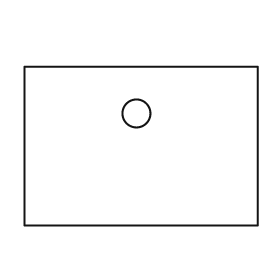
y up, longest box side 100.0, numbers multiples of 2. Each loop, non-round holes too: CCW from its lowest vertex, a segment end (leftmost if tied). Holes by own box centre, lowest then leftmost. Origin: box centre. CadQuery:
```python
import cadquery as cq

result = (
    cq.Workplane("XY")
    .moveTo(-50.0, -34.0)
    .lineTo(50.0, -34.0)
    .lineTo(50.0, 34.0)
    .lineTo(-50.0, 34.0)
    .close()
    .moveTo(-2.0, 14.0)
    .circle(6.0)
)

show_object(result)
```